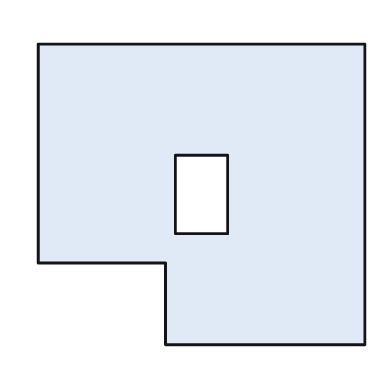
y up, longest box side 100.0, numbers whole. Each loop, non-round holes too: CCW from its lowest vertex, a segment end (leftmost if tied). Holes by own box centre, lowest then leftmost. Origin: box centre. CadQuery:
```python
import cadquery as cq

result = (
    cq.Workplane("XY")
    .moveTo(-11.0, -46.0)
    .lineTo(50.0, -46.0)
    .lineTo(50.0, 46.0)
    .lineTo(-50.0, 46.0)
    .lineTo(-50.0, -21.0)
    .lineTo(-11.0, -21.0)
    .close()
    .moveTo(-8.0, -12.0)
    .lineTo(8.0, -12.0)
    .lineTo(8.0, 12.0)
    .lineTo(-8.0, 12.0)
    .close()
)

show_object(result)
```